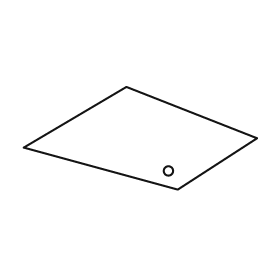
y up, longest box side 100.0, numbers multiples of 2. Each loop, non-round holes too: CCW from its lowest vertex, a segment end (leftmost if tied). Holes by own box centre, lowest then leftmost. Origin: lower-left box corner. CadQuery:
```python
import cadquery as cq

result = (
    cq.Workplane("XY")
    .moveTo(66.0, 0.0)
    .lineTo(100.0, 22.0)
    .lineTo(44.0, 44.0)
    .lineTo(0.0, 18.0)
    .close()
    .moveTo(62.0, 8.0)
    .circle(2.0)
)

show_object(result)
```